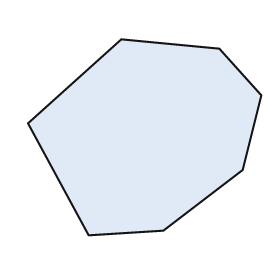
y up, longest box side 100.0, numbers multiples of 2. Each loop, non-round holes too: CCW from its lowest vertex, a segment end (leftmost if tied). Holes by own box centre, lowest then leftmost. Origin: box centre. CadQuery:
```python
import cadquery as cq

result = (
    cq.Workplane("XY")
    .moveTo(-24.0, -42.0)
    .lineTo(8.0, -40.0)
    .lineTo(42.0, -14.0)
    .lineTo(50.0, 18.0)
    .lineTo(32.0, 38.0)
    .lineTo(-10.0, 42.0)
    .lineTo(-50.0, 6.0)
    .close()
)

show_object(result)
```